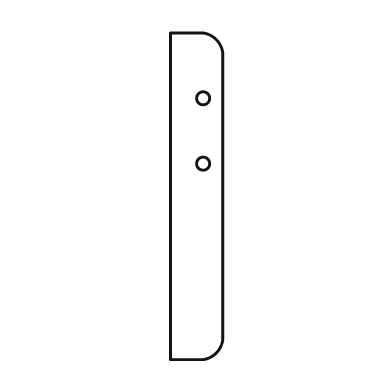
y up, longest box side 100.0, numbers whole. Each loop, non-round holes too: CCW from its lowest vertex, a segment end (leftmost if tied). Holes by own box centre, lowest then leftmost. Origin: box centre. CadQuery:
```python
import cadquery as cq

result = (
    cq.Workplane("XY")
    .moveTo(-8.0, -50.0)
    .lineTo(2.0, -50.0)
    .threePointArc((6.0, -48.0), (8.0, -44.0))
    .lineTo(8.0, 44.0)
    .threePointArc((6.0, 48.0), (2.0, 50.0))
    .lineTo(-8.0, 50.0)
    .close()
    .moveTo(2.0, 10.0)
    .circle(2.0)
    .moveTo(2.0, 30.0)
    .circle(2.0)
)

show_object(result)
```